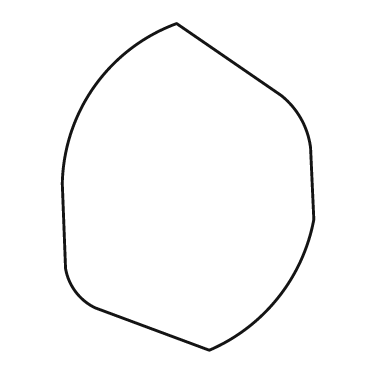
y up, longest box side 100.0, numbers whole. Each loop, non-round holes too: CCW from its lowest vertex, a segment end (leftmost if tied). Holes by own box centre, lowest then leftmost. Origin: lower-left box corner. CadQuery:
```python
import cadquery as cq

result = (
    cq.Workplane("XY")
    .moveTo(45.0, 0.0)
    .threePointArc((66.0, 16.0), (77.0, 40.0))
    .lineTo(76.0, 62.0)
    .threePointArc((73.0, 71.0), (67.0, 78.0))
    .lineTo(35.0, 100.0)
    .threePointArc((10.0, 81.0), (0.0, 51.0))
    .lineTo(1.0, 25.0)
    .threePointArc((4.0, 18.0), (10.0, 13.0))
    .close()
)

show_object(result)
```